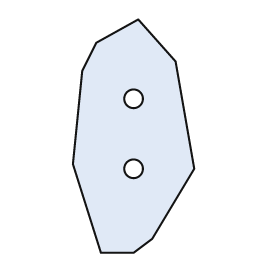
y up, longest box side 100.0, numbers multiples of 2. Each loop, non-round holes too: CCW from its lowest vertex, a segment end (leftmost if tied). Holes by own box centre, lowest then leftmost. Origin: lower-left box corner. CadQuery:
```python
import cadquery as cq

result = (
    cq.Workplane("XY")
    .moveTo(12.0, 0.0)
    .lineTo(26.0, 0.0)
    .lineTo(34.0, 6.0)
    .lineTo(52.0, 36.0)
    .lineTo(44.0, 82.0)
    .lineTo(28.0, 100.0)
    .lineTo(10.0, 90.0)
    .lineTo(4.0, 78.0)
    .lineTo(0.0, 38.0)
    .close()
    .moveTo(26.0, 36.0)
    .circle(4.0)
    .moveTo(26.0, 66.0)
    .circle(4.0)
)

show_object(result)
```